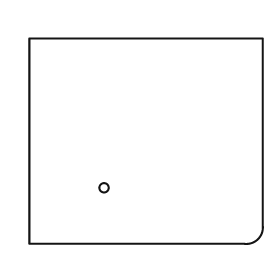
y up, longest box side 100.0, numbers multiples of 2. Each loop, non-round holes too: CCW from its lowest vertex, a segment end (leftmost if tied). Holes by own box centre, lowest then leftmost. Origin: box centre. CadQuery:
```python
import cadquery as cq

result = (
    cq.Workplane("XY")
    .moveTo(-50.0, -44.0)
    .lineTo(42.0, -44.0)
    .threePointArc((48.0, -42.0), (50.0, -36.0))
    .lineTo(50.0, 44.0)
    .lineTo(-50.0, 44.0)
    .close()
    .moveTo(-18.0, -20.0)
    .circle(2.0)
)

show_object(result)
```